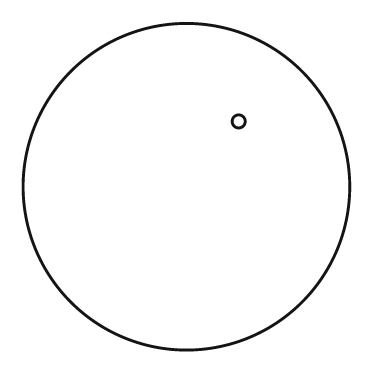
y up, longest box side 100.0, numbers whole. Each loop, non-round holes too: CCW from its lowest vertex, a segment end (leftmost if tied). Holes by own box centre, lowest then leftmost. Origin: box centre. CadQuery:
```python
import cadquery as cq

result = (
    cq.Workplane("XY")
    .moveTo(0.0, 0.0)
    .circle(50.0)
    .moveTo(16.0, 20.0)
    .circle(2.0)
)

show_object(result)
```